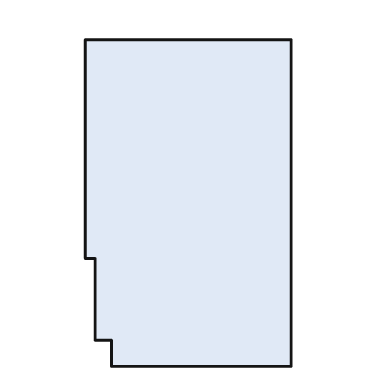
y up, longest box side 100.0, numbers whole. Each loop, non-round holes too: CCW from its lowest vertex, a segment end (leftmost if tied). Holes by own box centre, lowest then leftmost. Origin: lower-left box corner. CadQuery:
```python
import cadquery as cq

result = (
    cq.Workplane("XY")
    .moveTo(8.0, 0.0)
    .lineTo(63.0, 0.0)
    .lineTo(63.0, 100.0)
    .lineTo(0.0, 100.0)
    .lineTo(0.0, 33.0)
    .lineTo(3.0, 33.0)
    .lineTo(3.0, 8.0)
    .lineTo(8.0, 8.0)
    .close()
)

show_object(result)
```